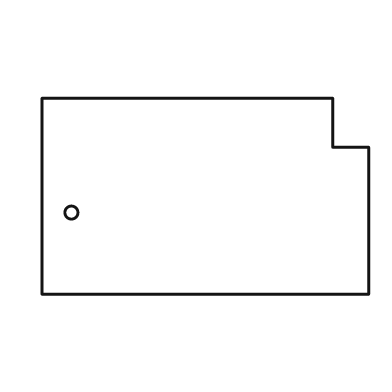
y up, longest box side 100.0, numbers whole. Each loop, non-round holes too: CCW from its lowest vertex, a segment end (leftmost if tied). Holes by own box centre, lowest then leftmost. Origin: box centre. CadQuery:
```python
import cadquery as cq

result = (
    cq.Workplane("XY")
    .moveTo(-50.0, -30.0)
    .lineTo(50.0, -30.0)
    .lineTo(50.0, 15.0)
    .lineTo(39.0, 15.0)
    .lineTo(39.0, 30.0)
    .lineTo(-50.0, 30.0)
    .close()
    .moveTo(-41.0, -5.0)
    .circle(2.0)
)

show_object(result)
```